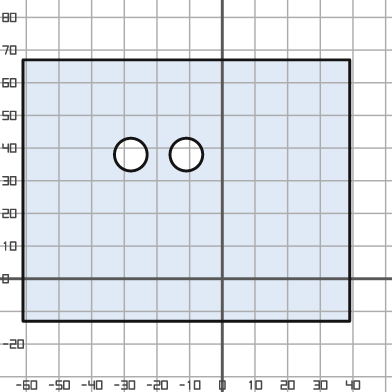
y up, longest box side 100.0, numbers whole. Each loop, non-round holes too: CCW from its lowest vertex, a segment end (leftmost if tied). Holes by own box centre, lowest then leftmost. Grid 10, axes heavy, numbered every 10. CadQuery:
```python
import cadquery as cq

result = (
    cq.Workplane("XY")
    .moveTo(-61.0, -13.0)
    .lineTo(39.0, -13.0)
    .lineTo(39.0, 67.0)
    .lineTo(-61.0, 67.0)
    .close()
    .moveTo(-28.0, 38.0)
    .circle(5.0)
    .moveTo(-11.0, 38.0)
    .circle(5.0)
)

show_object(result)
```